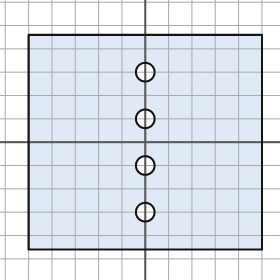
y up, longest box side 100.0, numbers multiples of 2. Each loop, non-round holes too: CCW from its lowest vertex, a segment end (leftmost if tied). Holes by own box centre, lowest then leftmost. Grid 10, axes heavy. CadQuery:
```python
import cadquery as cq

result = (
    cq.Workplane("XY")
    .moveTo(-50.0, -46.0)
    .lineTo(50.0, -46.0)
    .lineTo(50.0, 46.0)
    .lineTo(-50.0, 46.0)
    .close()
    .moveTo(0.0, -30.0)
    .circle(4.0)
    .moveTo(0.0, -10.0)
    .circle(4.0)
    .moveTo(0.0, 10.0)
    .circle(4.0)
    .moveTo(0.0, 30.0)
    .circle(4.0)
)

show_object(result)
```